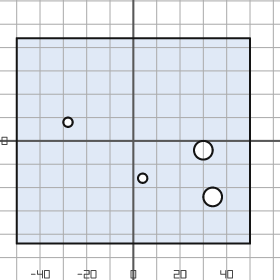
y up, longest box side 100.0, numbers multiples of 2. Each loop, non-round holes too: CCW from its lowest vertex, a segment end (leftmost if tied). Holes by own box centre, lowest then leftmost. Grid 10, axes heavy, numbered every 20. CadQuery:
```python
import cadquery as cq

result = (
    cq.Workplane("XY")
    .moveTo(-50.0, -44.0)
    .lineTo(50.0, -44.0)
    .lineTo(50.0, 44.0)
    .lineTo(-50.0, 44.0)
    .close()
    .moveTo(34.0, -24.0)
    .circle(4.0)
    .moveTo(4.0, -16.0)
    .circle(2.0)
    .moveTo(30.0, -4.0)
    .circle(4.0)
    .moveTo(-28.0, 8.0)
    .circle(2.0)
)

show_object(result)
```